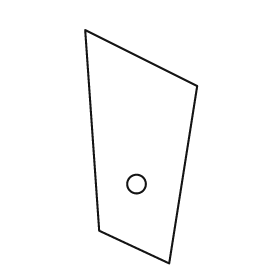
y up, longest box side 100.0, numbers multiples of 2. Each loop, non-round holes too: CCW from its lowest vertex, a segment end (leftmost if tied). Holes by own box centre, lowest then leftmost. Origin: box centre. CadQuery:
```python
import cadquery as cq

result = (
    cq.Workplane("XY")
    .moveTo(12.0, -50.0)
    .lineTo(24.0, 26.0)
    .lineTo(-24.0, 50.0)
    .lineTo(-18.0, -36.0)
    .close()
    .moveTo(-2.0, -16.0)
    .circle(4.0)
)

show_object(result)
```